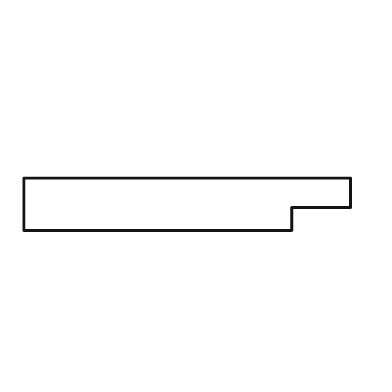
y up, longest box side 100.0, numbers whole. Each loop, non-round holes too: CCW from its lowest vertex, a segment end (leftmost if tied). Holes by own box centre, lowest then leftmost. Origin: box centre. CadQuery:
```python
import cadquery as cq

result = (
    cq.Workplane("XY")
    .moveTo(-50.0, -8.0)
    .lineTo(32.0, -8.0)
    .lineTo(32.0, -1.0)
    .lineTo(50.0, -1.0)
    .lineTo(50.0, 8.0)
    .lineTo(-50.0, 8.0)
    .close()
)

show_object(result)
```